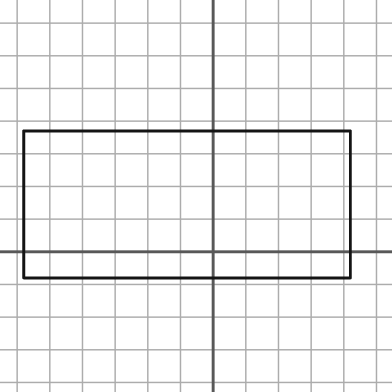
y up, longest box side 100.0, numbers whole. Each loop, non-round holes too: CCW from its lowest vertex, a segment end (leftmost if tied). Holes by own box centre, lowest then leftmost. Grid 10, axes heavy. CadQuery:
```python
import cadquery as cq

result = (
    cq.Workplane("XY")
    .moveTo(-58.0, -8.0)
    .lineTo(42.0, -8.0)
    .lineTo(42.0, 37.0)
    .lineTo(-58.0, 37.0)
    .close()
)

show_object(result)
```